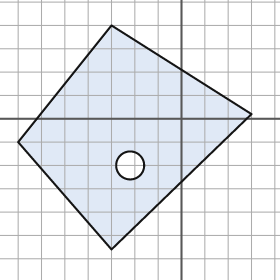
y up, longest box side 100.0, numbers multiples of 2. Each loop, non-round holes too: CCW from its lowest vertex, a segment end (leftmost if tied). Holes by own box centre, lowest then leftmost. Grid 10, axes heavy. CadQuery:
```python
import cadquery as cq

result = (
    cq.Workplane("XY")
    .moveTo(-30.0, -56.0)
    .lineTo(30.0, 2.0)
    .lineTo(-30.0, 40.0)
    .lineTo(-70.0, -10.0)
    .close()
    .moveTo(-22.0, -20.0)
    .circle(6.0)
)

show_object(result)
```